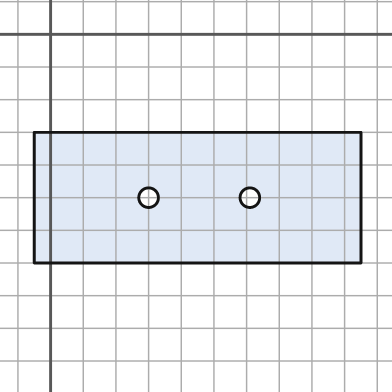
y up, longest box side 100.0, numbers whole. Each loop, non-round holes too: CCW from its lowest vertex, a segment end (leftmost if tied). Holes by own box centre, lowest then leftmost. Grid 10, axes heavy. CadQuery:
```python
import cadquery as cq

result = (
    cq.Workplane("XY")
    .moveTo(-5.0, -70.0)
    .lineTo(95.0, -70.0)
    .lineTo(95.0, -30.0)
    .lineTo(-5.0, -30.0)
    .close()
    .moveTo(30.0, -50.0)
    .circle(3.0)
    .moveTo(61.0, -50.0)
    .circle(3.0)
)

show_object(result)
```